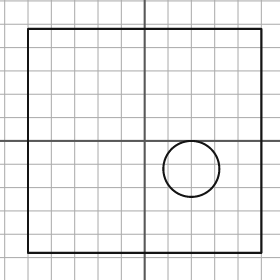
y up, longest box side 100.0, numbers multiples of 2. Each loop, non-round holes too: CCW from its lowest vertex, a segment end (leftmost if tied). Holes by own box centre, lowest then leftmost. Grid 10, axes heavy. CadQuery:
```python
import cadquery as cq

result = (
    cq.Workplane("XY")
    .moveTo(-50.0, -48.0)
    .lineTo(50.0, -48.0)
    .lineTo(50.0, 48.0)
    .lineTo(-50.0, 48.0)
    .close()
    .moveTo(20.0, -12.0)
    .circle(12.0)
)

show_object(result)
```